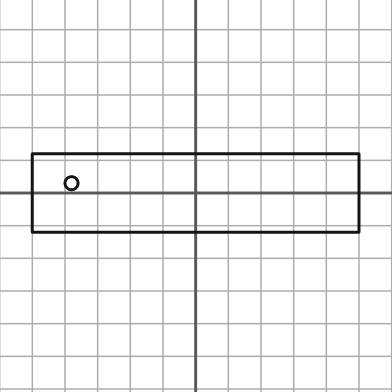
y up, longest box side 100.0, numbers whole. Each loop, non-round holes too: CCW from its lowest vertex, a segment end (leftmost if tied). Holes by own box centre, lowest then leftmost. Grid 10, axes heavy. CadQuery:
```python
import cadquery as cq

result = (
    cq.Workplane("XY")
    .moveTo(-50.0, -12.0)
    .lineTo(50.0, -12.0)
    .lineTo(50.0, 12.0)
    .lineTo(-50.0, 12.0)
    .close()
    .moveTo(-38.0, 3.0)
    .circle(2.0)
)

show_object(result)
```